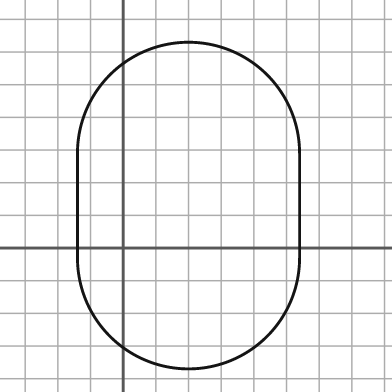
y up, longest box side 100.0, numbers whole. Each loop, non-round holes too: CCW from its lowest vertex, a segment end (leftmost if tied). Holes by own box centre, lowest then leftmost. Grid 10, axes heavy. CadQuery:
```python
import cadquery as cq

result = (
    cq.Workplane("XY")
    .moveTo(-14.0, -3.0)
    .threePointArc((20.0, -37.0), (54.0, -3.0))
    .lineTo(54.0, 29.0)
    .threePointArc((20.0, 63.0), (-14.0, 29.0))
    .close()
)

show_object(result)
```